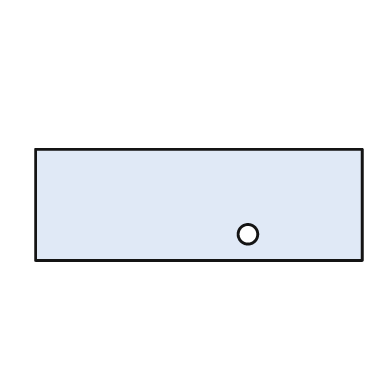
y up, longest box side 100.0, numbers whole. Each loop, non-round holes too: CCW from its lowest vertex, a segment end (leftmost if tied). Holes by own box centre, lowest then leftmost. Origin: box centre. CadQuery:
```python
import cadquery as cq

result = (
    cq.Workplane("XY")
    .moveTo(-50.0, -17.0)
    .lineTo(50.0, -17.0)
    .lineTo(50.0, 17.0)
    .lineTo(-50.0, 17.0)
    .close()
    .moveTo(15.0, -9.0)
    .circle(3.0)
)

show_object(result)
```